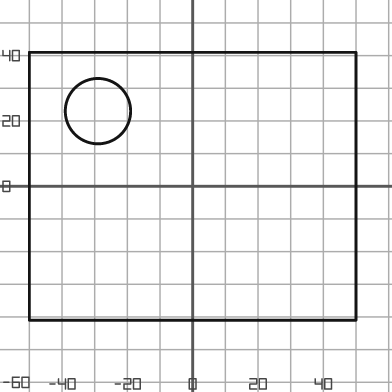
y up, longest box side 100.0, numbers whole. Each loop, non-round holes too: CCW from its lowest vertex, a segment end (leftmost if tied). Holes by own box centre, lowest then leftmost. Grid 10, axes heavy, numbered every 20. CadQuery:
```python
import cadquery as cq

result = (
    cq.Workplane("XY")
    .moveTo(-50.0, -41.0)
    .lineTo(50.0, -41.0)
    .lineTo(50.0, 41.0)
    .lineTo(-50.0, 41.0)
    .close()
    .moveTo(-29.0, 23.0)
    .circle(10.0)
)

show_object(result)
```